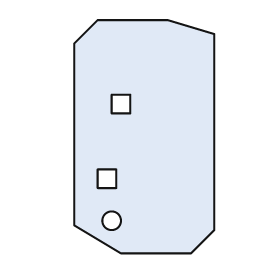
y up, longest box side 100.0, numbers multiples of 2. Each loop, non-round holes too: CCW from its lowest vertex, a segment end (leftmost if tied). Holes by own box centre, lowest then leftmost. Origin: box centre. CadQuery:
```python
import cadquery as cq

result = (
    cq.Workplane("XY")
    .moveTo(-10.0, -50.0)
    .lineTo(20.0, -50.0)
    .lineTo(30.0, -40.0)
    .lineTo(30.0, 44.0)
    .lineTo(10.0, 50.0)
    .lineTo(-20.0, 50.0)
    .lineTo(-30.0, 40.0)
    .lineTo(-30.0, -38.0)
    .close()
    .moveTo(-14.0, -36.0)
    .circle(4.0)
    .moveTo(-20.0, -22.0)
    .lineTo(-12.0, -22.0)
    .lineTo(-12.0, -14.0)
    .lineTo(-20.0, -14.0)
    .close()
    .moveTo(-14.0, 10.0)
    .lineTo(-6.0, 10.0)
    .lineTo(-6.0, 18.0)
    .lineTo(-14.0, 18.0)
    .close()
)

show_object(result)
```